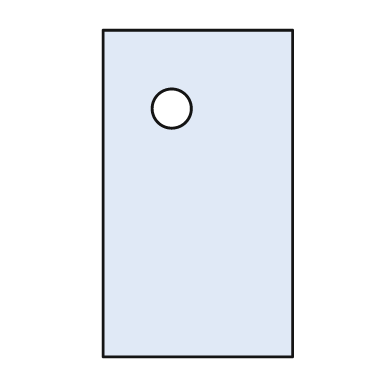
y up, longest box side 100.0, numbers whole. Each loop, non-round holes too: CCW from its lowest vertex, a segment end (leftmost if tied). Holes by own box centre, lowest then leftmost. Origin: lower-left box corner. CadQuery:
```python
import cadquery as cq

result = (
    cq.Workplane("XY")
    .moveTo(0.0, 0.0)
    .lineTo(58.0, 0.0)
    .lineTo(58.0, 100.0)
    .lineTo(0.0, 100.0)
    .close()
    .moveTo(21.0, 76.0)
    .circle(6.0)
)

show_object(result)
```